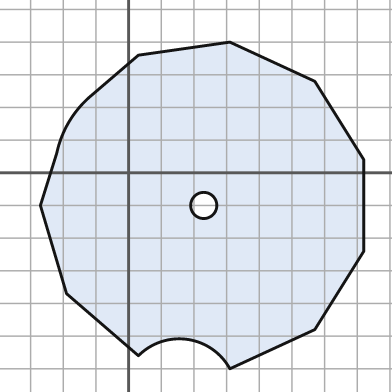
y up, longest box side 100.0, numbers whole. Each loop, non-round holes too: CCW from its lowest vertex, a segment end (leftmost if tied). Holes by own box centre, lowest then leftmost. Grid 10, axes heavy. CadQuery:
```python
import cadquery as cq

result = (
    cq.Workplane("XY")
    .moveTo(31.0, -60.0)
    .lineTo(57.0, -48.0)
    .lineTo(72.0, -24.0)
    .lineTo(72.0, 4.0)
    .lineTo(57.0, 28.0)
    .lineTo(31.0, 40.0)
    .lineTo(3.0, 36.0)
    .lineTo(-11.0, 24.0)
    .threePointArc((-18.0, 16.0), (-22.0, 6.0))
    .lineTo(-27.0, -10.0)
    .lineTo(-19.0, -37.0)
    .lineTo(3.0, -56.0)
    .threePointArc((18.0, -51.0), (31.0, -60.0))
    .close()
    .moveTo(23.0, -10.0)
    .circle(4.0)
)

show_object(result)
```